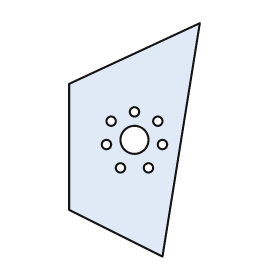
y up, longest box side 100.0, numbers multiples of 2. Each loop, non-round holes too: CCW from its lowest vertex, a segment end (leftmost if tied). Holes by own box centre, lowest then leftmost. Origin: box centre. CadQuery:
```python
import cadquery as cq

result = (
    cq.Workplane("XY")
    .moveTo(12.0, -50.0)
    .lineTo(28.0, 50.0)
    .lineTo(-28.0, 24.0)
    .lineTo(-28.0, -30.0)
    .close()
    .moveTo(-6.0, -12.0)
    .circle(2.0)
    .moveTo(6.0, -12.0)
    .circle(2.0)
    .moveTo(-12.0, -2.0)
    .circle(2.0)
    .moveTo(12.0, -2.0)
    .circle(2.0)
    .moveTo(0.0, 0.0)
    .circle(6.0)
    .moveTo(-10.0, 8.0)
    .circle(2.0)
    .moveTo(10.0, 8.0)
    .circle(2.0)
    .moveTo(0.0, 12.0)
    .circle(2.0)
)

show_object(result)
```